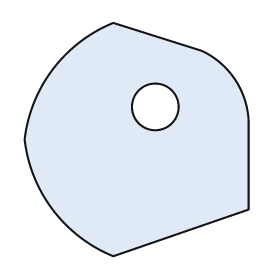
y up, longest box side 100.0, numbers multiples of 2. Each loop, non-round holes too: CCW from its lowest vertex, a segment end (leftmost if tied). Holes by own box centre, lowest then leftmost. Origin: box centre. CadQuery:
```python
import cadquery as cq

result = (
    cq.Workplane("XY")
    .moveTo(-10.0, -50.0)
    .lineTo(48.0, -30.0)
    .lineTo(48.0, 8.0)
    .threePointArc((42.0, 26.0), (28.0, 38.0))
    .lineTo(-10.0, 50.0)
    .threePointArc((-36.0, 30.0), (-48.0, 0.0))
    .threePointArc((-36.0, -30.0), (-10.0, -50.0))
    .close()
    .moveTo(8.0, 14.0)
    .circle(10.0)
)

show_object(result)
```